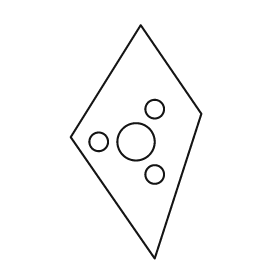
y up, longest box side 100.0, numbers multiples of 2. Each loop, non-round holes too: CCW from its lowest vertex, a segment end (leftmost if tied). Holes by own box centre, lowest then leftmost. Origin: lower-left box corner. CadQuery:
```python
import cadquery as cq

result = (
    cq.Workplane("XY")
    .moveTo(36.0, 0.0)
    .lineTo(56.0, 62.0)
    .lineTo(30.0, 100.0)
    .lineTo(0.0, 52.0)
    .close()
    .moveTo(36.0, 36.0)
    .circle(4.0)
    .moveTo(12.0, 50.0)
    .circle(4.0)
    .moveTo(28.0, 50.0)
    .circle(8.0)
    .moveTo(36.0, 64.0)
    .circle(4.0)
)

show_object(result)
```